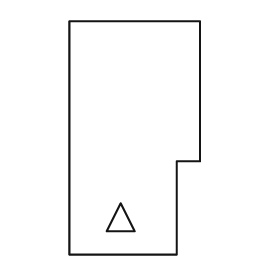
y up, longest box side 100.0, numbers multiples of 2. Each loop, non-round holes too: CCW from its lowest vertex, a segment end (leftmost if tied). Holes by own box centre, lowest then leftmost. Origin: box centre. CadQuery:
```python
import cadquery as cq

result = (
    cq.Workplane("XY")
    .moveTo(-28.0, -50.0)
    .lineTo(18.0, -50.0)
    .lineTo(18.0, -10.0)
    .lineTo(28.0, -10.0)
    .lineTo(28.0, 50.0)
    .lineTo(-28.0, 50.0)
    .close()
    .moveTo(-12.0, -40.0)
    .lineTo(0.0, -40.0)
    .lineTo(-6.0, -28.0)
    .close()
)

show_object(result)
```